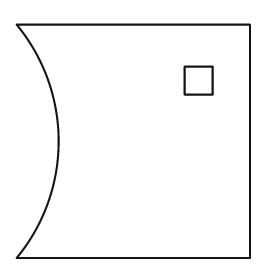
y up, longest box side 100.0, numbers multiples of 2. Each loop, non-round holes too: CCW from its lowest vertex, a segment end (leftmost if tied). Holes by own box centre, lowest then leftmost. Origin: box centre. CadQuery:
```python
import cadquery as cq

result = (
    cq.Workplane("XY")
    .moveTo(-50.0, -50.0)
    .lineTo(50.0, -50.0)
    .lineTo(50.0, 50.0)
    .lineTo(-50.0, 50.0)
    .threePointArc((-32.0, 0.0), (-50.0, -50.0))
    .close()
    .moveTo(22.0, 20.0)
    .lineTo(34.0, 20.0)
    .lineTo(34.0, 32.0)
    .lineTo(22.0, 32.0)
    .close()
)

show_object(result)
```